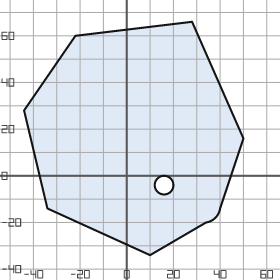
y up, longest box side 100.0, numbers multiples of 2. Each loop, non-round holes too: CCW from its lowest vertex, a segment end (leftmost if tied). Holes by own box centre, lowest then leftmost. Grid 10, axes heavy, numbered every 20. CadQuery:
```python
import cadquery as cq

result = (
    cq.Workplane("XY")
    .moveTo(10.0, -34.0)
    .lineTo(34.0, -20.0)
    .threePointArc((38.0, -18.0), (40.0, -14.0))
    .lineTo(50.0, 16.0)
    .lineTo(28.0, 66.0)
    .lineTo(-22.0, 60.0)
    .lineTo(-44.0, 28.0)
    .lineTo(-34.0, -14.0)
    .close()
    .moveTo(16.0, -4.0)
    .circle(4.0)
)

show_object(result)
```